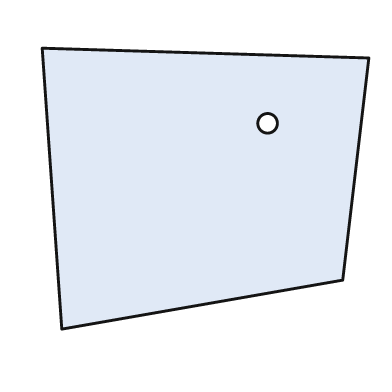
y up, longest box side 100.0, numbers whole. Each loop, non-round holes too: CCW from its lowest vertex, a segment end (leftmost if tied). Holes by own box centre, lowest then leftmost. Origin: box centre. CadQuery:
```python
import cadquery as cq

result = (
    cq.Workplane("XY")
    .moveTo(-44.0, -43.0)
    .lineTo(42.0, -28.0)
    .lineTo(50.0, 40.0)
    .lineTo(-50.0, 43.0)
    .close()
    .moveTo(19.0, 20.0)
    .circle(3.0)
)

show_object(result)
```